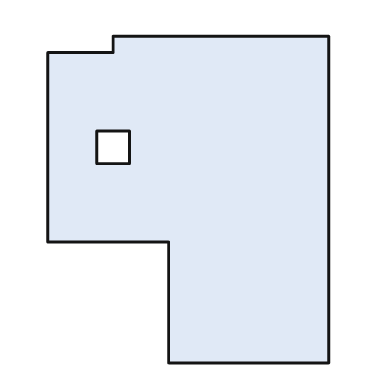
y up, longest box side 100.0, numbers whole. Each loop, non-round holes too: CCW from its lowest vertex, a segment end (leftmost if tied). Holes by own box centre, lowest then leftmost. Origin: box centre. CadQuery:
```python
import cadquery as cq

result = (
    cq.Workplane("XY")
    .moveTo(-6.0, -50.0)
    .lineTo(43.0, -50.0)
    .lineTo(43.0, 50.0)
    .lineTo(-23.0, 50.0)
    .lineTo(-23.0, 45.0)
    .lineTo(-43.0, 45.0)
    .lineTo(-43.0, -13.0)
    .lineTo(-6.0, -13.0)
    .close()
    .moveTo(-28.0, 11.0)
    .lineTo(-18.0, 11.0)
    .lineTo(-18.0, 21.0)
    .lineTo(-28.0, 21.0)
    .close()
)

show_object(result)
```